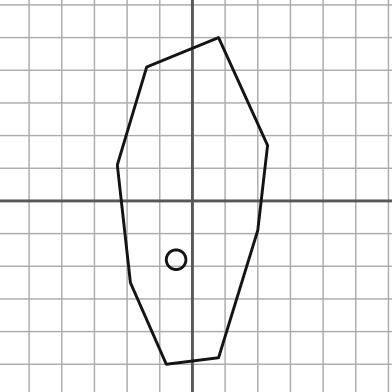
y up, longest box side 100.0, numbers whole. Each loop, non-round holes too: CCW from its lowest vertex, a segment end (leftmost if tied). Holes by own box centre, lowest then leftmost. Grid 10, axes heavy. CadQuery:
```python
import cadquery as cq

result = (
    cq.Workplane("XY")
    .moveTo(-8.0, -50.0)
    .lineTo(8.0, -48.0)
    .lineTo(20.0, -9.0)
    .lineTo(23.0, 17.0)
    .lineTo(8.0, 50.0)
    .lineTo(-14.0, 41.0)
    .lineTo(-23.0, 11.0)
    .lineTo(-19.0, -25.0)
    .close()
    .moveTo(-5.0, -18.0)
    .circle(3.0)
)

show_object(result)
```